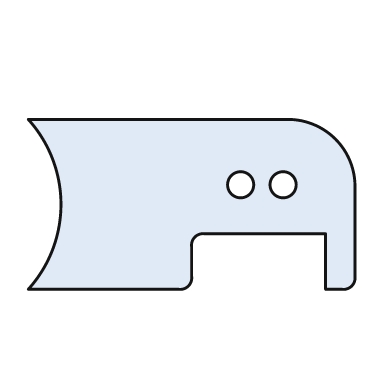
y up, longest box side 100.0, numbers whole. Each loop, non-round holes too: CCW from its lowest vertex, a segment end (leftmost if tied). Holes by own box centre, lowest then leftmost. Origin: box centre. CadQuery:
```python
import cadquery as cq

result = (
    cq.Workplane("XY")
    .moveTo(-50.0, -26.0)
    .lineTo(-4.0, -26.0)
    .threePointArc((-1.0, -25.0), (0.0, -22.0))
    .lineTo(0.0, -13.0)
    .threePointArc((1.0, -10.0), (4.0, -9.0))
    .lineTo(41.0, -9.0)
    .lineTo(41.0, -26.0)
    .lineTo(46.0, -26.0)
    .threePointArc((49.0, -25.0), (50.0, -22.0))
    .lineTo(50.0, 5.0)
    .threePointArc((44.0, 20.0), (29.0, 26.0))
    .lineTo(-50.0, 26.0)
    .threePointArc((-40.0, 0.0), (-50.0, -26.0))
    .close()
    .moveTo(15.0, 6.0)
    .circle(4.0)
    .moveTo(28.0, 6.0)
    .circle(4.0)
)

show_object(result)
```